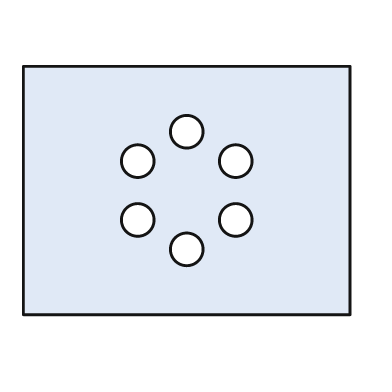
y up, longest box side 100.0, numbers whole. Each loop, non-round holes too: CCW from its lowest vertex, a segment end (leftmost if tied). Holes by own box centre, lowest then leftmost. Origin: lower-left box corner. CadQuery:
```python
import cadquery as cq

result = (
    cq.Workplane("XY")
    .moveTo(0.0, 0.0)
    .lineTo(100.0, 0.0)
    .lineTo(100.0, 76.0)
    .lineTo(0.0, 76.0)
    .close()
    .moveTo(50.0, 20.0)
    .circle(5.0)
    .moveTo(35.0, 29.0)
    .circle(5.0)
    .moveTo(65.0, 29.0)
    .circle(5.0)
    .moveTo(35.0, 47.0)
    .circle(5.0)
    .moveTo(65.0, 47.0)
    .circle(5.0)
    .moveTo(50.0, 56.0)
    .circle(5.0)
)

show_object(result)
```